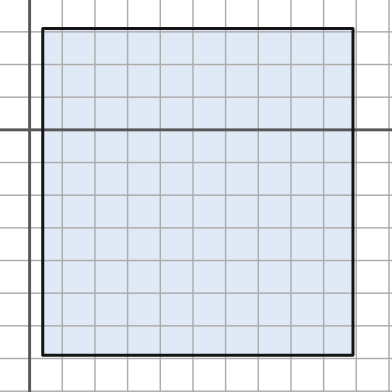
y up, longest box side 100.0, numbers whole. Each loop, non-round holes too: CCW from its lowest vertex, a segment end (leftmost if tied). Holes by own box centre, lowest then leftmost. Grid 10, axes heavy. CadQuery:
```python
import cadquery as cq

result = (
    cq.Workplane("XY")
    .moveTo(4.0, -69.0)
    .lineTo(99.0, -69.0)
    .lineTo(99.0, 31.0)
    .lineTo(4.0, 31.0)
    .close()
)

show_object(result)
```